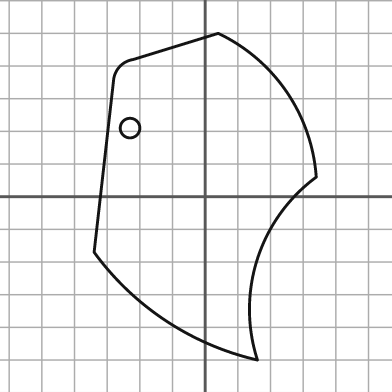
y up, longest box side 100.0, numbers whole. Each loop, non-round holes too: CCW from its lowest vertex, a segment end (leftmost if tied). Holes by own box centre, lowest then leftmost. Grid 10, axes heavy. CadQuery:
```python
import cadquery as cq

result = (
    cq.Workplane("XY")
    .moveTo(16.0, -50.0)
    .threePointArc((16.0, -19.0), (34.0, 6.0))
    .threePointArc((25.0, 32.0), (4.0, 50.0))
    .lineTo(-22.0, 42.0)
    .threePointArc((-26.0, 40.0), (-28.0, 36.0))
    .lineTo(-34.0, -17.0)
    .threePointArc((-12.0, -38.0), (16.0, -50.0))
    .close()
    .moveTo(-23.0, 21.0)
    .circle(3.0)
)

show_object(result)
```